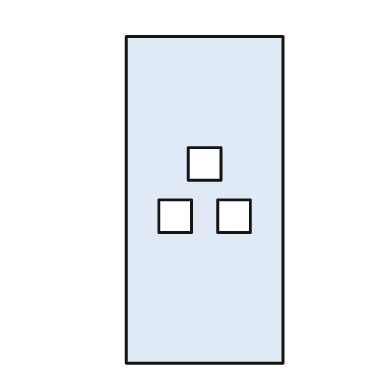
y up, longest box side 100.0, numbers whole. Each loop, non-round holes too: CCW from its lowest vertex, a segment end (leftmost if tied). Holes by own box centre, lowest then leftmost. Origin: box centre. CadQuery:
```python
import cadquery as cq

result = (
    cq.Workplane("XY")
    .moveTo(-24.0, -50.0)
    .lineTo(24.0, -50.0)
    .lineTo(24.0, 50.0)
    .lineTo(-24.0, 50.0)
    .close()
    .moveTo(-14.0, -10.0)
    .lineTo(-4.0, -10.0)
    .lineTo(-4.0, 0.0)
    .lineTo(-14.0, 0.0)
    .close()
    .moveTo(4.0, -10.0)
    .lineTo(14.0, -10.0)
    .lineTo(14.0, 0.0)
    .lineTo(4.0, 0.0)
    .close()
    .moveTo(-5.0, 6.0)
    .lineTo(5.0, 6.0)
    .lineTo(5.0, 16.0)
    .lineTo(-5.0, 16.0)
    .close()
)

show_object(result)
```